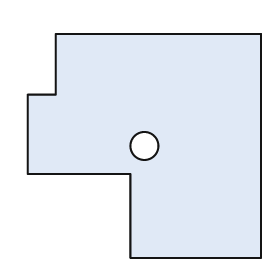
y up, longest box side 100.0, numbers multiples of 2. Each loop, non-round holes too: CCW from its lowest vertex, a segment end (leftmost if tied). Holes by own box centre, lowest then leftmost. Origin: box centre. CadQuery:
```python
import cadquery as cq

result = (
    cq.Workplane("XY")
    .moveTo(-6.0, -48.0)
    .lineTo(50.0, -48.0)
    .lineTo(50.0, 48.0)
    .lineTo(-38.0, 48.0)
    .lineTo(-38.0, 22.0)
    .lineTo(-50.0, 22.0)
    .lineTo(-50.0, -12.0)
    .lineTo(-6.0, -12.0)
    .close()
    .moveTo(0.0, 0.0)
    .circle(6.0)
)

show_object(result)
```